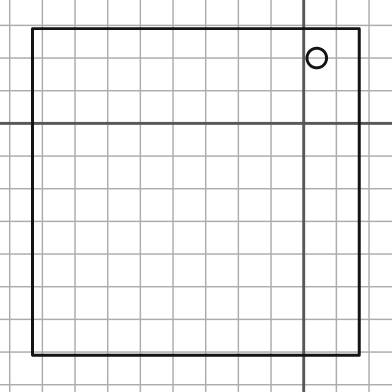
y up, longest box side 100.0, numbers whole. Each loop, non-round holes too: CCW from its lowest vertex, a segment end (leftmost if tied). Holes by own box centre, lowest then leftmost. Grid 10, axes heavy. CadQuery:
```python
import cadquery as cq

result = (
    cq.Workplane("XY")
    .moveTo(-83.0, -71.0)
    .lineTo(17.0, -71.0)
    .lineTo(17.0, 29.0)
    .lineTo(-83.0, 29.0)
    .close()
    .moveTo(4.0, 20.0)
    .circle(3.0)
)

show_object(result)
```